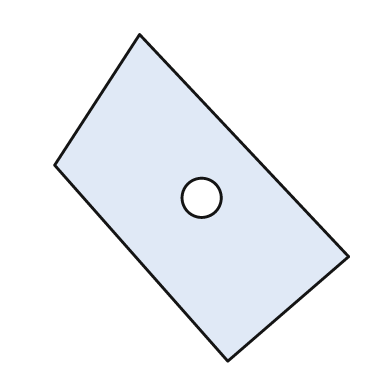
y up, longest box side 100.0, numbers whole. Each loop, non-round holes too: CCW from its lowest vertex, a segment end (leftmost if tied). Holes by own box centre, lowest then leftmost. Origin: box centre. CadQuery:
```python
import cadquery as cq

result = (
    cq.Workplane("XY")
    .moveTo(8.0, -50.0)
    .lineTo(45.0, -18.0)
    .lineTo(-19.0, 50.0)
    .lineTo(-45.0, 10.0)
    .close()
    .moveTo(0.0, 0.0)
    .circle(6.0)
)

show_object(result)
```